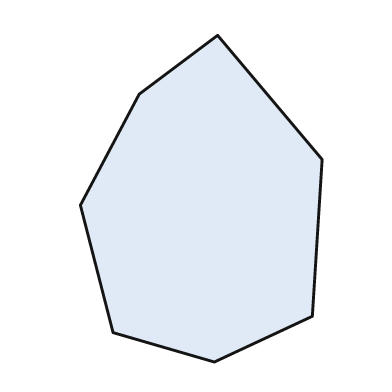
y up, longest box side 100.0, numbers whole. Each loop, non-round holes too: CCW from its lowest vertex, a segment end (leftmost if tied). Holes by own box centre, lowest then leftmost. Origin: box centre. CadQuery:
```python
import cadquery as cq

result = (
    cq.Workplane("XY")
    .moveTo(4.0, -50.0)
    .lineTo(34.0, -36.0)
    .lineTo(37.0, 12.0)
    .lineTo(5.0, 50.0)
    .lineTo(-19.0, 32.0)
    .lineTo(-37.0, -2.0)
    .lineTo(-27.0, -41.0)
    .close()
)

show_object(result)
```